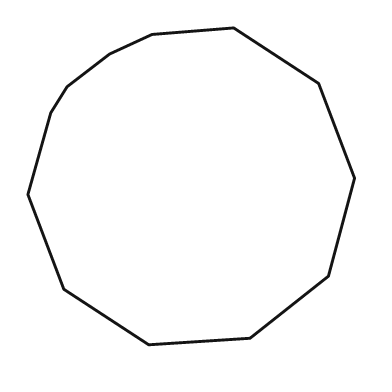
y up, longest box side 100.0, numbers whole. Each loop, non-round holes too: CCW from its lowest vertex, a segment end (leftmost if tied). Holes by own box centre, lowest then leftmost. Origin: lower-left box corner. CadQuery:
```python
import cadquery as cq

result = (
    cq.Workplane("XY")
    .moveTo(37.0, 0.0)
    .lineTo(68.0, 2.0)
    .lineTo(92.0, 21.0)
    .lineTo(100.0, 51.0)
    .lineTo(89.0, 80.0)
    .lineTo(63.0, 97.0)
    .lineTo(38.0, 95.0)
    .lineTo(25.0, 89.0)
    .lineTo(12.0, 79.0)
    .lineTo(7.0, 71.0)
    .lineTo(0.0, 46.0)
    .lineTo(11.0, 17.0)
    .close()
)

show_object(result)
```